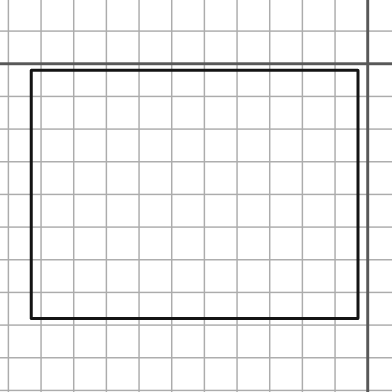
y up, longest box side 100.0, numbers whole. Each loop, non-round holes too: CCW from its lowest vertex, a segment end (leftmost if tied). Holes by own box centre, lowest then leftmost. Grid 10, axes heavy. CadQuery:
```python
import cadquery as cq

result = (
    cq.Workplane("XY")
    .moveTo(-103.0, -78.0)
    .lineTo(-3.0, -78.0)
    .lineTo(-3.0, -2.0)
    .lineTo(-103.0, -2.0)
    .close()
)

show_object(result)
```